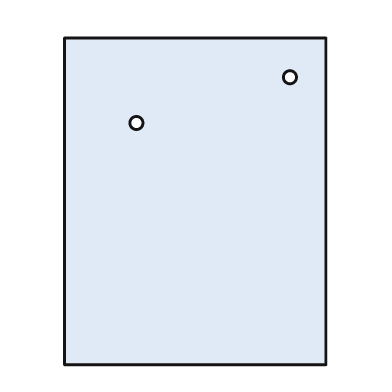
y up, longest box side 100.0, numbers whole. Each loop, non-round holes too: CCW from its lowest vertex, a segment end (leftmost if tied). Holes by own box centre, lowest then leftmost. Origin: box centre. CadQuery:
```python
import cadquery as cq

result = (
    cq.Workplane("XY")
    .moveTo(-40.0, -50.0)
    .lineTo(40.0, -50.0)
    .lineTo(40.0, 50.0)
    .lineTo(-40.0, 50.0)
    .close()
    .moveTo(-18.0, 24.0)
    .circle(2.0)
    .moveTo(29.0, 38.0)
    .circle(2.0)
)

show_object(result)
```